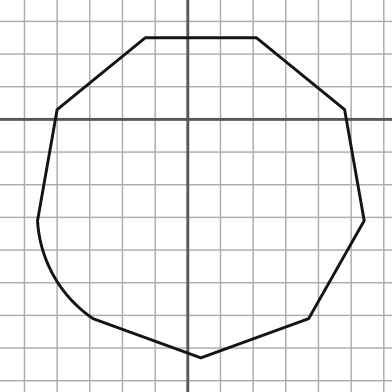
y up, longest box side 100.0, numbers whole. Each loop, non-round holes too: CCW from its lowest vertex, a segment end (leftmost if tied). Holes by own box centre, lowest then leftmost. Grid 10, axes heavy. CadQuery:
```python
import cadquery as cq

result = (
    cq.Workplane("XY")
    .moveTo(4.0, -73.0)
    .lineTo(37.0, -61.0)
    .lineTo(54.0, -31.0)
    .lineTo(48.0, 3.0)
    .lineTo(21.0, 25.0)
    .lineTo(-13.0, 25.0)
    .lineTo(-40.0, 3.0)
    .lineTo(-46.0, -31.0)
    .threePointArc((-41.0, -48.0), (-29.0, -61.0))
    .close()
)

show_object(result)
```